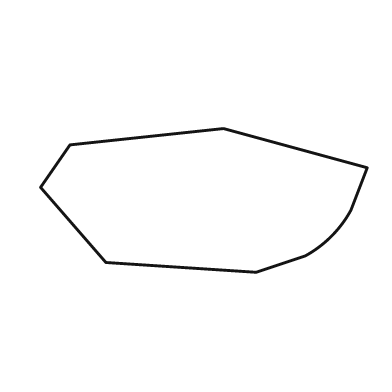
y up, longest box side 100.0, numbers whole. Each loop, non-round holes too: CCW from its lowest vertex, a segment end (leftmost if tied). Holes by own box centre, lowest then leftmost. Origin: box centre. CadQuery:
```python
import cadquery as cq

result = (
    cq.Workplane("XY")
    .moveTo(16.0, -22.0)
    .lineTo(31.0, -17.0)
    .threePointArc((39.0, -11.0), (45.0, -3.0))
    .lineTo(50.0, 10.0)
    .lineTo(6.0, 22.0)
    .lineTo(-41.0, 17.0)
    .lineTo(-50.0, 4.0)
    .lineTo(-30.0, -19.0)
    .close()
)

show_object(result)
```